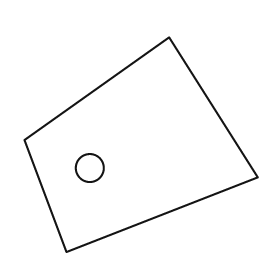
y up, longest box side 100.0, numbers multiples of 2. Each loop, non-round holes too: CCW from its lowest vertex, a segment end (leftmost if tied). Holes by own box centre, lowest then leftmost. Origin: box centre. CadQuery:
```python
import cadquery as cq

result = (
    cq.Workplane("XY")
    .moveTo(-32.0, -46.0)
    .lineTo(50.0, -14.0)
    .lineTo(12.0, 46.0)
    .lineTo(-50.0, 2.0)
    .close()
    .moveTo(-22.0, -10.0)
    .circle(6.0)
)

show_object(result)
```